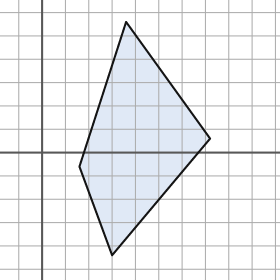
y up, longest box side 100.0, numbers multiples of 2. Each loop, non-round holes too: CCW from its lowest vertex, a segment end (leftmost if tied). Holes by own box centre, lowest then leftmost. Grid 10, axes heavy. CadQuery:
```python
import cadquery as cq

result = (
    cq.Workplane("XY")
    .moveTo(30.0, -44.0)
    .lineTo(72.0, 6.0)
    .lineTo(36.0, 56.0)
    .lineTo(16.0, -6.0)
    .close()
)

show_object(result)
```